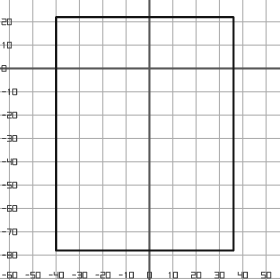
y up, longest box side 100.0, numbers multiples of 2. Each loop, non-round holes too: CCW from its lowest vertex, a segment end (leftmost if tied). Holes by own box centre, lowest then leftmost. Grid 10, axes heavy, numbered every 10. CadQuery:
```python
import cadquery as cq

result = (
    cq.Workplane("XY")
    .moveTo(-40.0, -78.0)
    .lineTo(36.0, -78.0)
    .lineTo(36.0, 22.0)
    .lineTo(-40.0, 22.0)
    .close()
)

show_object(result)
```